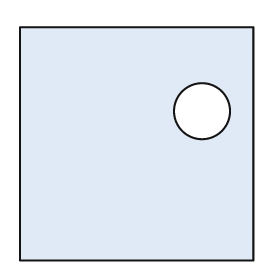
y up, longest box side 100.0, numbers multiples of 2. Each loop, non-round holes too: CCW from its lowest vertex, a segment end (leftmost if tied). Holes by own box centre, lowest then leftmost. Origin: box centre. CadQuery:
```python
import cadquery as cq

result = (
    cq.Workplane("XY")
    .moveTo(-50.0, -50.0)
    .lineTo(50.0, -50.0)
    .lineTo(50.0, 50.0)
    .lineTo(-50.0, 50.0)
    .close()
    .moveTo(28.0, 14.0)
    .circle(12.0)
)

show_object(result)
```